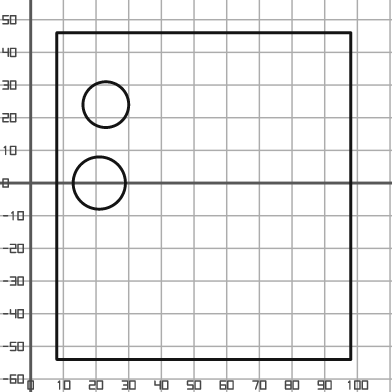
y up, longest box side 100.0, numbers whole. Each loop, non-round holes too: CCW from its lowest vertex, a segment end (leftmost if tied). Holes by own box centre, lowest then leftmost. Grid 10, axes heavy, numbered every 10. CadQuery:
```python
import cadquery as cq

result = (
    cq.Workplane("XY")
    .moveTo(8.0, -54.0)
    .lineTo(98.0, -54.0)
    .lineTo(98.0, 46.0)
    .lineTo(8.0, 46.0)
    .close()
    .moveTo(21.0, 0.0)
    .circle(8.0)
    .moveTo(23.0, 24.0)
    .circle(7.0)
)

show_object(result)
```